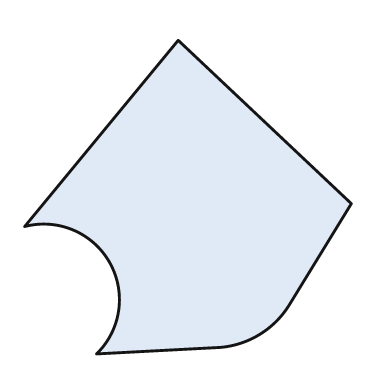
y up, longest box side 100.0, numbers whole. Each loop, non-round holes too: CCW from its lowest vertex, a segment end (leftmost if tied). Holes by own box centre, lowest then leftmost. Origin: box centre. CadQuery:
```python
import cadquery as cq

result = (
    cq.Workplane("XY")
    .moveTo(-28.0, -48.0)
    .lineTo(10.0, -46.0)
    .threePointArc((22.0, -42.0), (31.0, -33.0))
    .lineTo(50.0, -2.0)
    .lineTo(-3.0, 48.0)
    .lineTo(-50.0, -9.0)
    .threePointArc((-24.0, -20.0), (-28.0, -48.0))
    .close()
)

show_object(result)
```